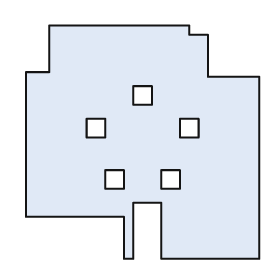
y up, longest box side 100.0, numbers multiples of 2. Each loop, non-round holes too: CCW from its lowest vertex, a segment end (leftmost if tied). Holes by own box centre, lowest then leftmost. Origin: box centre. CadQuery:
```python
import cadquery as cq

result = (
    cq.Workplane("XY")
    .moveTo(-8.0, -50.0)
    .lineTo(-4.0, -50.0)
    .lineTo(-4.0, -26.0)
    .lineTo(8.0, -26.0)
    .lineTo(8.0, -50.0)
    .lineTo(50.0, -50.0)
    .lineTo(50.0, 28.0)
    .lineTo(28.0, 28.0)
    .lineTo(28.0, 46.0)
    .lineTo(20.0, 46.0)
    .lineTo(20.0, 50.0)
    .lineTo(-40.0, 50.0)
    .lineTo(-40.0, 30.0)
    .lineTo(-50.0, 30.0)
    .lineTo(-50.0, -32.0)
    .lineTo(-8.0, -32.0)
    .close()
    .moveTo(-16.0, -20.0)
    .lineTo(-8.0, -20.0)
    .lineTo(-8.0, -12.0)
    .lineTo(-16.0, -12.0)
    .close()
    .moveTo(8.0, -20.0)
    .lineTo(16.0, -20.0)
    .lineTo(16.0, -12.0)
    .lineTo(8.0, -12.0)
    .close()
    .moveTo(-24.0, 2.0)
    .lineTo(-16.0, 2.0)
    .lineTo(-16.0, 10.0)
    .lineTo(-24.0, 10.0)
    .close()
    .moveTo(16.0, 2.0)
    .lineTo(24.0, 2.0)
    .lineTo(24.0, 10.0)
    .lineTo(16.0, 10.0)
    .close()
    .moveTo(-4.0, 16.0)
    .lineTo(4.0, 16.0)
    .lineTo(4.0, 24.0)
    .lineTo(-4.0, 24.0)
    .close()
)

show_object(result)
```